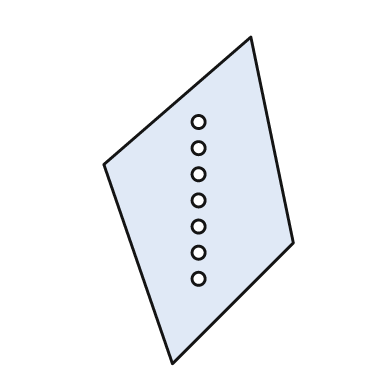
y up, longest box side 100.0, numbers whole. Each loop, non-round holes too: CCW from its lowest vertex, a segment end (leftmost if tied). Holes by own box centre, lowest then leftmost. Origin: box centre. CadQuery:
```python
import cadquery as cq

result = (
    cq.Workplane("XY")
    .moveTo(-8.0, -50.0)
    .lineTo(29.0, -13.0)
    .lineTo(16.0, 50.0)
    .lineTo(-29.0, 11.0)
    .close()
    .moveTo(0.0, -24.0)
    .circle(2.0)
    .moveTo(0.0, -16.0)
    .circle(2.0)
    .moveTo(0.0, -8.0)
    .circle(2.0)
    .moveTo(0.0, 0.0)
    .circle(2.0)
    .moveTo(0.0, 8.0)
    .circle(2.0)
    .moveTo(0.0, 16.0)
    .circle(2.0)
    .moveTo(0.0, 24.0)
    .circle(2.0)
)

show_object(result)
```